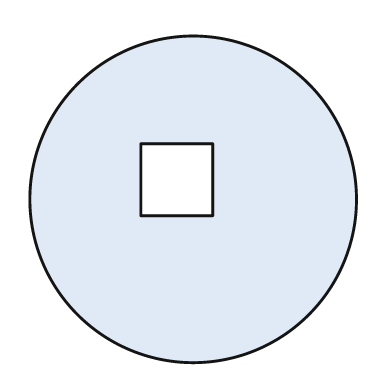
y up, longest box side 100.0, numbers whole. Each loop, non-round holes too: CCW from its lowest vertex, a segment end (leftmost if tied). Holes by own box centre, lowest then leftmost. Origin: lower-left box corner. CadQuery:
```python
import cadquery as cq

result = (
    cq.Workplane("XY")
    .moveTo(50.0, 50.0)
    .circle(50.0)
    .moveTo(34.0, 45.0)
    .lineTo(56.0, 45.0)
    .lineTo(56.0, 67.0)
    .lineTo(34.0, 67.0)
    .close()
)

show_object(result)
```